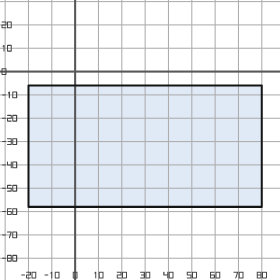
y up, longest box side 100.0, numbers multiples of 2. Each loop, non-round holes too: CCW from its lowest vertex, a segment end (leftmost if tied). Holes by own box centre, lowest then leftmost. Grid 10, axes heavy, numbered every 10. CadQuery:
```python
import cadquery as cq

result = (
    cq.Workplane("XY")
    .moveTo(-20.0, -58.0)
    .lineTo(80.0, -58.0)
    .lineTo(80.0, -6.0)
    .lineTo(-20.0, -6.0)
    .close()
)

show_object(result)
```